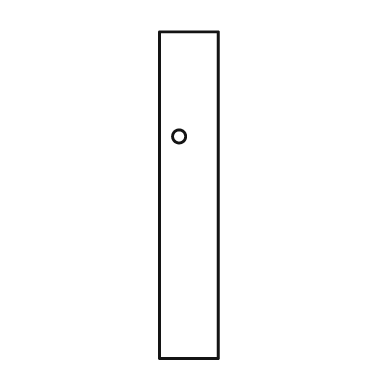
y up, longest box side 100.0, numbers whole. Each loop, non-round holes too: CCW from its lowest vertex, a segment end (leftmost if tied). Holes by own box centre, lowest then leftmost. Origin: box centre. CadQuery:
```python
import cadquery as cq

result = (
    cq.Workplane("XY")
    .moveTo(-9.0, -50.0)
    .lineTo(9.0, -50.0)
    .lineTo(9.0, 50.0)
    .lineTo(-9.0, 50.0)
    .close()
    .moveTo(-3.0, 18.0)
    .circle(2.0)
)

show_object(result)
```